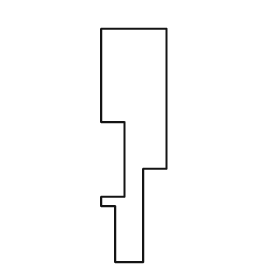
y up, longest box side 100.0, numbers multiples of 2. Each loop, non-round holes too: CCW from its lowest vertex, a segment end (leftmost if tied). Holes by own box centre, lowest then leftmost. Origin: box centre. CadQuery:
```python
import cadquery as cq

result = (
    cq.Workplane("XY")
    .moveTo(-8.0, -50.0)
    .lineTo(4.0, -50.0)
    .lineTo(4.0, -10.0)
    .lineTo(14.0, -10.0)
    .lineTo(14.0, 50.0)
    .lineTo(-14.0, 50.0)
    .lineTo(-14.0, 10.0)
    .lineTo(-4.0, 10.0)
    .lineTo(-4.0, -22.0)
    .lineTo(-14.0, -22.0)
    .lineTo(-14.0, -26.0)
    .lineTo(-8.0, -26.0)
    .close()
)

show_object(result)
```